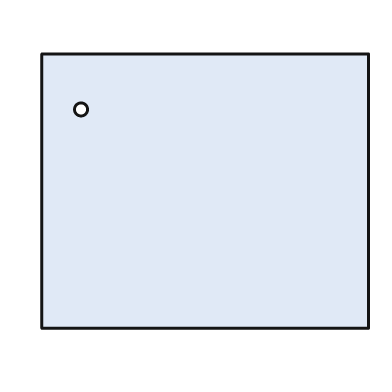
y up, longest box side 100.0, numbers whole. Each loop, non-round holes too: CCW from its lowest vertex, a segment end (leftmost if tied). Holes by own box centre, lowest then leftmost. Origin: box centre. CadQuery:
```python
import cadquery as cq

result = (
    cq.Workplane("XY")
    .moveTo(-50.0, -42.0)
    .lineTo(50.0, -42.0)
    .lineTo(50.0, 42.0)
    .lineTo(-50.0, 42.0)
    .close()
    .moveTo(-38.0, 25.0)
    .circle(2.0)
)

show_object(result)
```